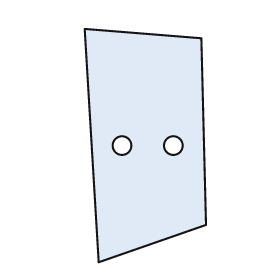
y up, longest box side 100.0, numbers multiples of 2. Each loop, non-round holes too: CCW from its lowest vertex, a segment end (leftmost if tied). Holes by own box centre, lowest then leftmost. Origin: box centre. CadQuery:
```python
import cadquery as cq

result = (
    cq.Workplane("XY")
    .moveTo(-20.0, -50.0)
    .lineTo(26.0, -34.0)
    .lineTo(24.0, 46.0)
    .lineTo(-26.0, 50.0)
    .close()
    .moveTo(-10.0, 0.0)
    .circle(4.0)
    .moveTo(12.0, 0.0)
    .circle(4.0)
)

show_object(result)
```